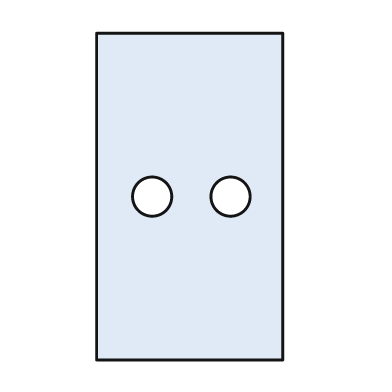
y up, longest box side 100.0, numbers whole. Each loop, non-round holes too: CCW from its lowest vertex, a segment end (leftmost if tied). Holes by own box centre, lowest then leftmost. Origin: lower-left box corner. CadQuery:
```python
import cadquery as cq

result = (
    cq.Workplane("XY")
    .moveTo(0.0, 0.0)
    .lineTo(57.0, 0.0)
    .lineTo(57.0, 100.0)
    .lineTo(0.0, 100.0)
    .close()
    .moveTo(17.0, 50.0)
    .circle(6.0)
    .moveTo(41.0, 50.0)
    .circle(6.0)
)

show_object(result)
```